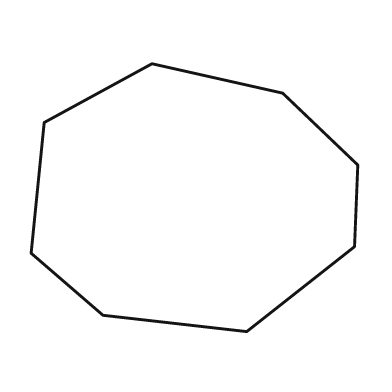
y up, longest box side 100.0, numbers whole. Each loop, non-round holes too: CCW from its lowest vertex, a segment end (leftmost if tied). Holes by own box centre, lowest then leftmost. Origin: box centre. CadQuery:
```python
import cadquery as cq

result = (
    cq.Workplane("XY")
    .moveTo(16.0, -41.0)
    .lineTo(49.0, -15.0)
    .lineTo(50.0, 10.0)
    .lineTo(27.0, 32.0)
    .lineTo(-13.0, 41.0)
    .lineTo(-46.0, 23.0)
    .lineTo(-50.0, -17.0)
    .lineTo(-28.0, -36.0)
    .close()
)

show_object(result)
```